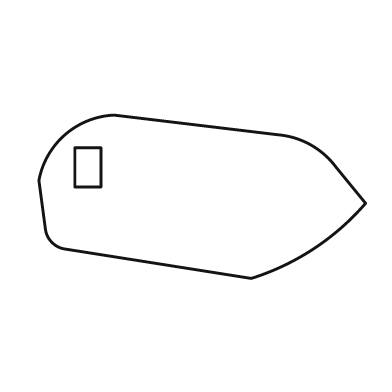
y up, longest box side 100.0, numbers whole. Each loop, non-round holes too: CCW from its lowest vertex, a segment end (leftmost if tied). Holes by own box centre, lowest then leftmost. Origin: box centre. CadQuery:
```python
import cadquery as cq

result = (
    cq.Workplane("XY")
    .moveTo(15.0, -25.0)
    .threePointArc((34.0, -16.0), (50.0, -2.0))
    .lineTo(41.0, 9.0)
    .threePointArc((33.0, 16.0), (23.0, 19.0))
    .lineTo(-27.0, 25.0)
    .threePointArc((-42.0, 19.0), (-50.0, 5.0))
    .lineTo(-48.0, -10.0)
    .threePointArc((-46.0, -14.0), (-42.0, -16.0))
    .close()
    .moveTo(-39.0, 3.0)
    .lineTo(-31.0, 3.0)
    .lineTo(-31.0, 15.0)
    .lineTo(-39.0, 15.0)
    .close()
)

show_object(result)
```